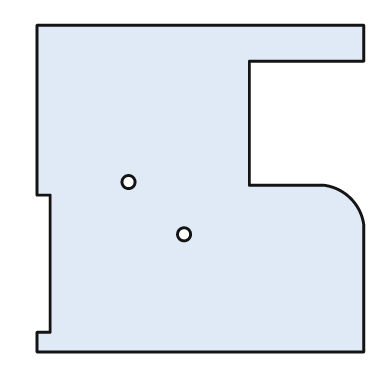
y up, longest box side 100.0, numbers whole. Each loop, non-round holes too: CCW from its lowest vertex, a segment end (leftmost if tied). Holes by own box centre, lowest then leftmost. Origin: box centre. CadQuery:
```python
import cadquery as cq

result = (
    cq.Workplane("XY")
    .moveTo(-50.0, -50.0)
    .lineTo(50.0, -50.0)
    .lineTo(50.0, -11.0)
    .threePointArc((46.0, -3.0), (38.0, 1.0))
    .lineTo(15.0, 1.0)
    .lineTo(15.0, 39.0)
    .lineTo(50.0, 39.0)
    .lineTo(50.0, 50.0)
    .lineTo(-50.0, 50.0)
    .lineTo(-50.0, -2.0)
    .lineTo(-46.0, -2.0)
    .lineTo(-46.0, -44.0)
    .lineTo(-50.0, -44.0)
    .close()
    .moveTo(-5.0, -14.0)
    .circle(2.0)
    .moveTo(-22.0, 2.0)
    .circle(2.0)
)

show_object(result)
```